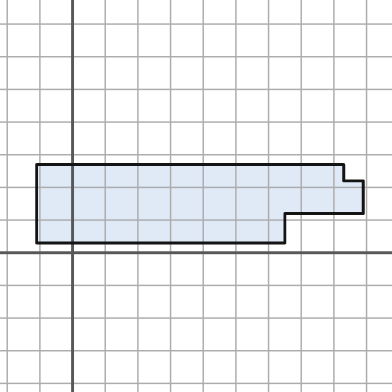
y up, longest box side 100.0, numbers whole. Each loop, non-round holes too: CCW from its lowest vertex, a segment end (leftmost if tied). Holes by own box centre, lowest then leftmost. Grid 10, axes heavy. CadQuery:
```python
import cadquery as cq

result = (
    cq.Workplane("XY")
    .moveTo(-11.0, 3.0)
    .lineTo(65.0, 3.0)
    .lineTo(65.0, 12.0)
    .lineTo(89.0, 12.0)
    .lineTo(89.0, 22.0)
    .lineTo(83.0, 22.0)
    .lineTo(83.0, 27.0)
    .lineTo(-11.0, 27.0)
    .close()
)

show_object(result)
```